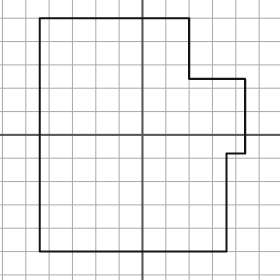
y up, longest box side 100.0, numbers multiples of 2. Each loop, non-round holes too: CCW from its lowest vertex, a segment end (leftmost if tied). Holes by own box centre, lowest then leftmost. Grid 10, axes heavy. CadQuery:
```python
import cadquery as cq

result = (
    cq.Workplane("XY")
    .moveTo(-44.0, -50.0)
    .lineTo(36.0, -50.0)
    .lineTo(36.0, -8.0)
    .lineTo(44.0, -8.0)
    .lineTo(44.0, 24.0)
    .lineTo(20.0, 24.0)
    .lineTo(20.0, 50.0)
    .lineTo(-44.0, 50.0)
    .close()
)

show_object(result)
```